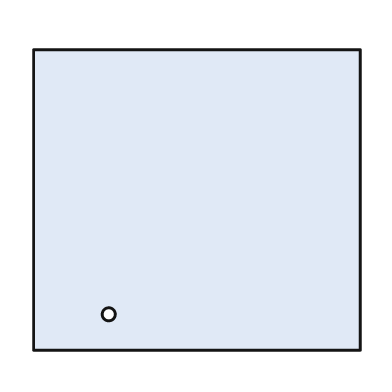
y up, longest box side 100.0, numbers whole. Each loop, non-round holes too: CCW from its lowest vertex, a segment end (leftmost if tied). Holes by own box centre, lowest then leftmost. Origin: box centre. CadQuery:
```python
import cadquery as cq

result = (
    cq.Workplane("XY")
    .moveTo(-50.0, -46.0)
    .lineTo(50.0, -46.0)
    .lineTo(50.0, 46.0)
    .lineTo(-50.0, 46.0)
    .close()
    .moveTo(-27.0, -35.0)
    .circle(2.0)
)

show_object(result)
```